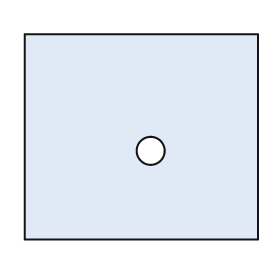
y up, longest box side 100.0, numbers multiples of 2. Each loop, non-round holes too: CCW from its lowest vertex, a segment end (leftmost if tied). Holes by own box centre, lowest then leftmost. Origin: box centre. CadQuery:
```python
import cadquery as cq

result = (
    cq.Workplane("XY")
    .moveTo(-50.0, -44.0)
    .lineTo(50.0, -44.0)
    .lineTo(50.0, 44.0)
    .lineTo(-50.0, 44.0)
    .close()
    .moveTo(4.0, -6.0)
    .circle(6.0)
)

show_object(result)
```